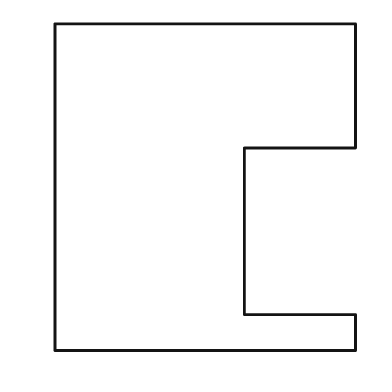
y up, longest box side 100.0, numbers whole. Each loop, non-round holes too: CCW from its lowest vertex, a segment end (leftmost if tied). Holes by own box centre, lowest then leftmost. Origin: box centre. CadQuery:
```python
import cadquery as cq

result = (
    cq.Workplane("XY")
    .moveTo(-46.0, -50.0)
    .lineTo(46.0, -50.0)
    .lineTo(46.0, -39.0)
    .lineTo(12.0, -39.0)
    .lineTo(12.0, 12.0)
    .lineTo(46.0, 12.0)
    .lineTo(46.0, 50.0)
    .lineTo(-46.0, 50.0)
    .close()
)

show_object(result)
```